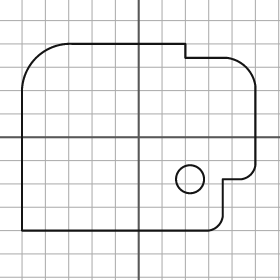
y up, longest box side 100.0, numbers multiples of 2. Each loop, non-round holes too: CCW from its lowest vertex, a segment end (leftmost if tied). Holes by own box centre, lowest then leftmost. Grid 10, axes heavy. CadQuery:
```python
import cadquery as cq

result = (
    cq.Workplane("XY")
    .moveTo(-50.0, -40.0)
    .lineTo(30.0, -40.0)
    .threePointArc((34.0, -38.0), (36.0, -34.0))
    .lineTo(36.0, -18.0)
    .lineTo(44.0, -18.0)
    .threePointArc((48.0, -16.0), (50.0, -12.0))
    .lineTo(50.0, 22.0)
    .threePointArc((46.0, 30.0), (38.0, 34.0))
    .lineTo(20.0, 34.0)
    .lineTo(20.0, 40.0)
    .lineTo(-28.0, 40.0)
    .threePointArc((-44.0, 34.0), (-50.0, 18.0))
    .close()
    .moveTo(22.0, -18.0)
    .circle(6.0)
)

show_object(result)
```